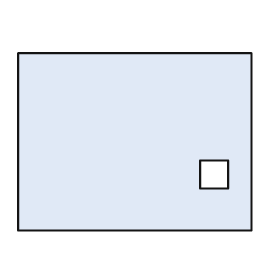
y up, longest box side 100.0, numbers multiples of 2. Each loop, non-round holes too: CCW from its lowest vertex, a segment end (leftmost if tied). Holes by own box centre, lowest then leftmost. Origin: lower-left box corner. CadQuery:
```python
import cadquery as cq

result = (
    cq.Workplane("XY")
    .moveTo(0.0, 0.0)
    .lineTo(100.0, 0.0)
    .lineTo(100.0, 76.0)
    .lineTo(0.0, 76.0)
    .close()
    .moveTo(78.0, 18.0)
    .lineTo(90.0, 18.0)
    .lineTo(90.0, 30.0)
    .lineTo(78.0, 30.0)
    .close()
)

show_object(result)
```